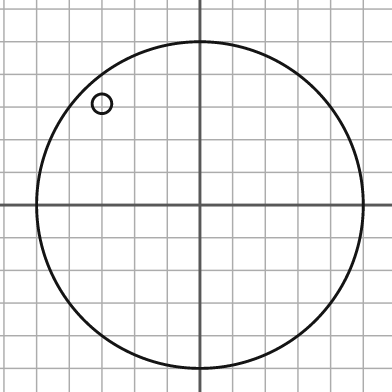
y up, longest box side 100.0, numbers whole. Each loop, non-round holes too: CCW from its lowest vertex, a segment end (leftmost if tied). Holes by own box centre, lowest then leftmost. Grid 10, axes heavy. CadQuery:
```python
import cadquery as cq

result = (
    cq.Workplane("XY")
    .moveTo(0.0, 0.0)
    .circle(50.0)
    .moveTo(-30.0, 31.0)
    .circle(3.0)
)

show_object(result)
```